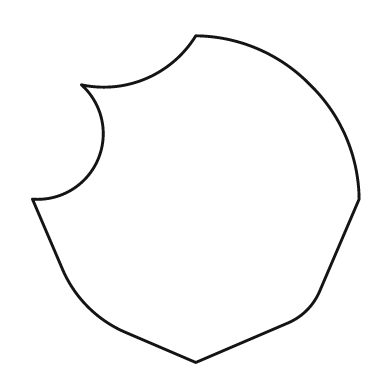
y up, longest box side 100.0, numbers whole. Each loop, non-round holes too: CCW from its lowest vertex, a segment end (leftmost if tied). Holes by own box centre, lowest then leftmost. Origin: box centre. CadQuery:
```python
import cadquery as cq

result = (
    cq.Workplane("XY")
    .moveTo(0.0, -50.0)
    .lineTo(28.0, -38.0)
    .threePointArc((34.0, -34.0), (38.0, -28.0))
    .lineTo(50.0, 0.0)
    .threePointArc((46.0, 19.0), (35.0, 35.0))
    .threePointArc((19.0, 46.0), (0.0, 50.0))
    .threePointArc((-15.0, 37.0), (-35.0, 35.0))
    .threePointArc((-30.0, 12.0), (-50.0, 0.0))
    .lineTo(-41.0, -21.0)
    .threePointArc((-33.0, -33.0), (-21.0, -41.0))
    .close()
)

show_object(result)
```